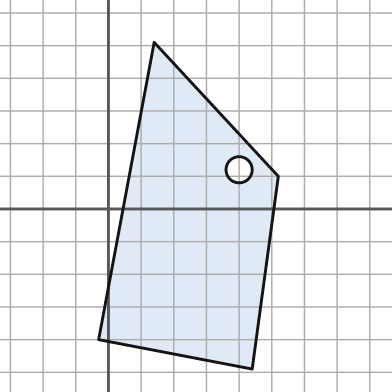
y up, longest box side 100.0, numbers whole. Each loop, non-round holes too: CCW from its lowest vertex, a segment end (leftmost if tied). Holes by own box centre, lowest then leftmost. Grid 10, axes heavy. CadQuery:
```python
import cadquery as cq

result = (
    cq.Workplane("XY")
    .moveTo(44.0, -49.0)
    .lineTo(52.0, 10.0)
    .lineTo(14.0, 51.0)
    .lineTo(-3.0, -40.0)
    .close()
    .moveTo(40.0, 12.0)
    .circle(4.0)
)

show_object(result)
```